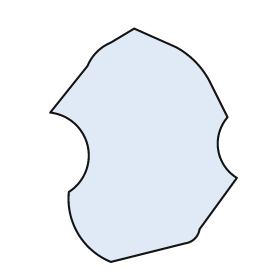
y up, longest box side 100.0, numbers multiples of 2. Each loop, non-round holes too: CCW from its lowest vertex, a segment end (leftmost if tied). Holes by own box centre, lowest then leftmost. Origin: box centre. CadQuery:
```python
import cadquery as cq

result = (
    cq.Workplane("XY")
    .moveTo(-14.0, -50.0)
    .lineTo(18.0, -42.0)
    .threePointArc((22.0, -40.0), (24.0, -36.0))
    .lineTo(40.0, -14.0)
    .threePointArc((32.0, -2.0), (36.0, 12.0))
    .lineTo(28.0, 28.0)
    .threePointArc((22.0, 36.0), (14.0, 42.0))
    .lineTo(-4.0, 50.0)
    .lineTo(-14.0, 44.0)
    .threePointArc((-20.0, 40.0), (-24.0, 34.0))
    .lineTo(-40.0, 14.0)
    .threePointArc((-24.0, 0.0), (-32.0, -20.0))
    .threePointArc((-28.0, -38.0), (-14.0, -50.0))
    .close()
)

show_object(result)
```